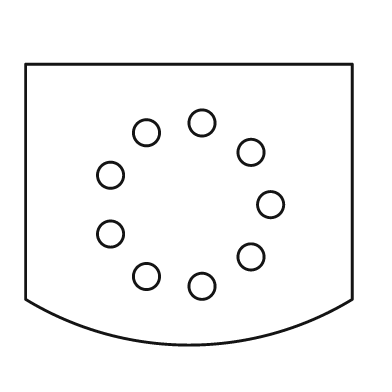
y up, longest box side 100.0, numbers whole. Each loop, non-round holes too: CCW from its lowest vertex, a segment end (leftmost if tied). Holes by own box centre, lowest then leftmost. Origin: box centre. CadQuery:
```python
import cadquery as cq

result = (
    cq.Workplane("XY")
    .moveTo(-50.0, -29.0)
    .threePointArc((0.0, -43.0), (50.0, -29.0))
    .lineTo(50.0, 43.0)
    .lineTo(-50.0, 43.0)
    .close()
    .moveTo(4.0, -25.0)
    .circle(4.0)
    .moveTo(-13.0, -22.0)
    .circle(4.0)
    .moveTo(19.0, -16.0)
    .circle(4.0)
    .moveTo(-24.0, -9.0)
    .circle(4.0)
    .moveTo(25.0, 0.0)
    .circle(4.0)
    .moveTo(-24.0, 9.0)
    .circle(4.0)
    .moveTo(19.0, 16.0)
    .circle(4.0)
    .moveTo(-13.0, 22.0)
    .circle(4.0)
    .moveTo(4.0, 25.0)
    .circle(4.0)
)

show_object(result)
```